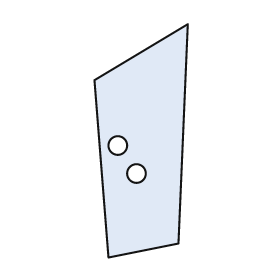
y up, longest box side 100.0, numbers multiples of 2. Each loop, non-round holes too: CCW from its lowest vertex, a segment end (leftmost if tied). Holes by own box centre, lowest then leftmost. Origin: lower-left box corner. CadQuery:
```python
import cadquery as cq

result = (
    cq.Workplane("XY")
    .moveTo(6.0, 0.0)
    .lineTo(36.0, 6.0)
    .lineTo(40.0, 100.0)
    .lineTo(0.0, 76.0)
    .close()
    .moveTo(18.0, 36.0)
    .circle(4.0)
    .moveTo(10.0, 48.0)
    .circle(4.0)
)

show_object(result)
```